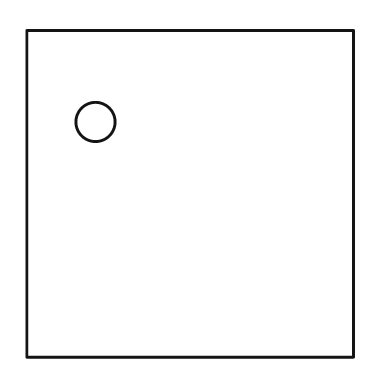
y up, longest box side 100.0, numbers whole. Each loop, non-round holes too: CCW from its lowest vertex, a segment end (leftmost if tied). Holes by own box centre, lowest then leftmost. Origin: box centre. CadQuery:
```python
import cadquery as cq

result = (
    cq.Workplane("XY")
    .moveTo(-50.0, -50.0)
    .lineTo(50.0, -50.0)
    .lineTo(50.0, 50.0)
    .lineTo(-50.0, 50.0)
    .close()
    .moveTo(-29.0, 22.0)
    .circle(6.0)
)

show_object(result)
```